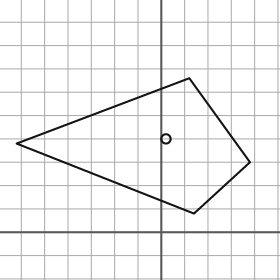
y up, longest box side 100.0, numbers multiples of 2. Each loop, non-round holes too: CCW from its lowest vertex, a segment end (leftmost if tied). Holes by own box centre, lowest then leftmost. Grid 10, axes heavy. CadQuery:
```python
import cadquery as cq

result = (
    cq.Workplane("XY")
    .moveTo(14.0, 8.0)
    .lineTo(38.0, 30.0)
    .lineTo(12.0, 66.0)
    .lineTo(-62.0, 38.0)
    .close()
    .moveTo(2.0, 40.0)
    .circle(2.0)
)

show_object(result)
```